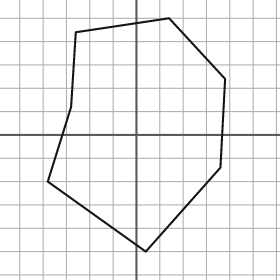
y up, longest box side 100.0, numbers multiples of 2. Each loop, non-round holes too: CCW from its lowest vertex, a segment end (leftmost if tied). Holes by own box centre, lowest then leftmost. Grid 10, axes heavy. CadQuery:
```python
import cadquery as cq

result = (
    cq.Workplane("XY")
    .moveTo(4.0, -50.0)
    .lineTo(36.0, -14.0)
    .lineTo(38.0, 24.0)
    .lineTo(14.0, 50.0)
    .lineTo(-26.0, 44.0)
    .lineTo(-28.0, 12.0)
    .lineTo(-38.0, -20.0)
    .close()
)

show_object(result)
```